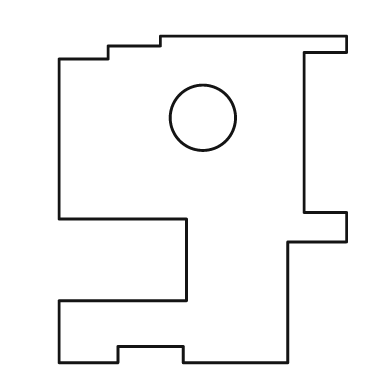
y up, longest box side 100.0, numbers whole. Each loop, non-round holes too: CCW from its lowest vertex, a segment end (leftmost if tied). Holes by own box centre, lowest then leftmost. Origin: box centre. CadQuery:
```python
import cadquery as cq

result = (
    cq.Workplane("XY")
    .moveTo(-44.0, -50.0)
    .lineTo(-26.0, -50.0)
    .lineTo(-26.0, -45.0)
    .lineTo(-6.0, -45.0)
    .lineTo(-6.0, -50.0)
    .lineTo(26.0, -50.0)
    .lineTo(26.0, -13.0)
    .lineTo(44.0, -13.0)
    .lineTo(44.0, -4.0)
    .lineTo(31.0, -4.0)
    .lineTo(31.0, 45.0)
    .lineTo(44.0, 45.0)
    .lineTo(44.0, 50.0)
    .lineTo(-13.0, 50.0)
    .lineTo(-13.0, 47.0)
    .lineTo(-29.0, 47.0)
    .lineTo(-29.0, 43.0)
    .lineTo(-44.0, 43.0)
    .lineTo(-44.0, -6.0)
    .lineTo(-5.0, -6.0)
    .lineTo(-5.0, -31.0)
    .lineTo(-44.0, -31.0)
    .close()
    .moveTo(0.0, 25.0)
    .circle(10.0)
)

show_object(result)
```